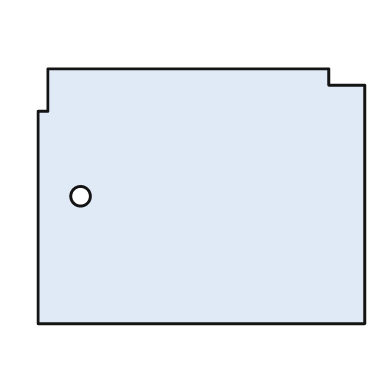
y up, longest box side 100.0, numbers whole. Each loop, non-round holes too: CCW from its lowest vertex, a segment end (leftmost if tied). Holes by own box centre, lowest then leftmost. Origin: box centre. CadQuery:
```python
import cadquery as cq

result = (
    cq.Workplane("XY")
    .moveTo(-50.0, -39.0)
    .lineTo(50.0, -39.0)
    .lineTo(50.0, 34.0)
    .lineTo(39.0, 34.0)
    .lineTo(39.0, 39.0)
    .lineTo(-47.0, 39.0)
    .lineTo(-47.0, 26.0)
    .lineTo(-50.0, 26.0)
    .close()
    .moveTo(-37.0, 0.0)
    .circle(3.0)
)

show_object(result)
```